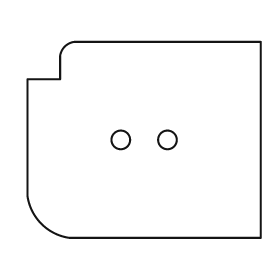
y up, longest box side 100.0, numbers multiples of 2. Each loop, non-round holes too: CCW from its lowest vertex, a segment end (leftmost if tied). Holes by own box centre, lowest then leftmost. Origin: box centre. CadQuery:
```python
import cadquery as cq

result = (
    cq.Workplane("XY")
    .moveTo(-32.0, -42.0)
    .lineTo(50.0, -42.0)
    .lineTo(50.0, 42.0)
    .lineTo(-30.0, 42.0)
    .threePointArc((-34.0, 40.0), (-36.0, 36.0))
    .lineTo(-36.0, 26.0)
    .lineTo(-50.0, 26.0)
    .lineTo(-50.0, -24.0)
    .threePointArc((-44.0, -36.0), (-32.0, -42.0))
    .close()
    .moveTo(-10.0, 0.0)
    .circle(4.0)
    .moveTo(10.0, 0.0)
    .circle(4.0)
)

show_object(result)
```